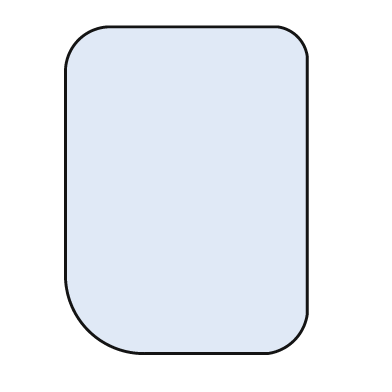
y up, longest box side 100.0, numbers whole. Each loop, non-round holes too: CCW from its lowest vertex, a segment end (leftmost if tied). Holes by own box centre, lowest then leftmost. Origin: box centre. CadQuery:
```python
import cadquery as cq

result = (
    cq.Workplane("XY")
    .moveTo(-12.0, -50.0)
    .lineTo(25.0, -50.0)
    .threePointArc((33.0, -46.0), (37.0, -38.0))
    .lineTo(37.0, 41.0)
    .threePointArc((34.0, 47.0), (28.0, 50.0))
    .lineTo(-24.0, 50.0)
    .threePointArc((-33.0, 46.0), (-37.0, 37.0))
    .lineTo(-37.0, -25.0)
    .threePointArc((-30.0, -43.0), (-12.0, -50.0))
    .close()
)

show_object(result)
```